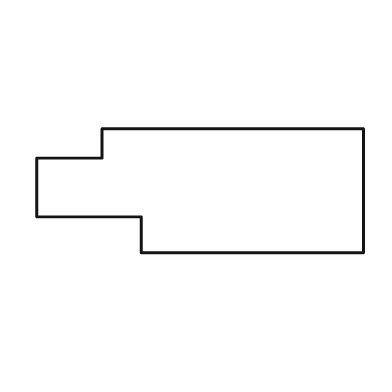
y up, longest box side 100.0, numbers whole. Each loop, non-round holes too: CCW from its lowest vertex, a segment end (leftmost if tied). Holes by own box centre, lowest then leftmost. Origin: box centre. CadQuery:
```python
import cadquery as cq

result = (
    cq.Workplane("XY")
    .moveTo(-18.0, -19.0)
    .lineTo(50.0, -19.0)
    .lineTo(50.0, 19.0)
    .lineTo(-30.0, 19.0)
    .lineTo(-30.0, 10.0)
    .lineTo(-50.0, 10.0)
    .lineTo(-50.0, -8.0)
    .lineTo(-18.0, -8.0)
    .close()
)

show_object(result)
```